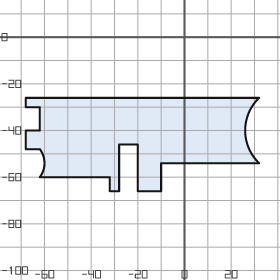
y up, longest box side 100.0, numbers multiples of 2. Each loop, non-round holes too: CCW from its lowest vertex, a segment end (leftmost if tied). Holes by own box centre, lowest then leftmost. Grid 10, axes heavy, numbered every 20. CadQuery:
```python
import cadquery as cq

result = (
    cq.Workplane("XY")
    .moveTo(-32.0, -66.0)
    .lineTo(-28.0, -66.0)
    .lineTo(-28.0, -46.0)
    .lineTo(-20.0, -46.0)
    .lineTo(-20.0, -66.0)
    .lineTo(-10.0, -66.0)
    .lineTo(-10.0, -54.0)
    .lineTo(32.0, -54.0)
    .threePointArc((26.0, -40.0), (32.0, -26.0))
    .lineTo(-68.0, -26.0)
    .lineTo(-68.0, -30.0)
    .lineTo(-62.0, -30.0)
    .lineTo(-62.0, -40.0)
    .lineTo(-68.0, -40.0)
    .lineTo(-68.0, -48.0)
    .lineTo(-62.0, -48.0)
    .threePointArc((-60.0, -54.0), (-62.0, -60.0))
    .lineTo(-32.0, -60.0)
    .close()
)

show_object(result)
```